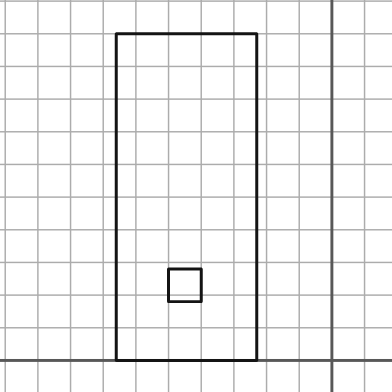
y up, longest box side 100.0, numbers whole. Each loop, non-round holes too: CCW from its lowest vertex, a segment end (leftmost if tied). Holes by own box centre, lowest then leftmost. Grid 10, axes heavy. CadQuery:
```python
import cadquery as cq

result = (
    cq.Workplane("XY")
    .moveTo(-66.0, 0.0)
    .lineTo(-23.0, 0.0)
    .lineTo(-23.0, 100.0)
    .lineTo(-66.0, 100.0)
    .close()
    .moveTo(-50.0, 18.0)
    .lineTo(-40.0, 18.0)
    .lineTo(-40.0, 28.0)
    .lineTo(-50.0, 28.0)
    .close()
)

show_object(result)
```